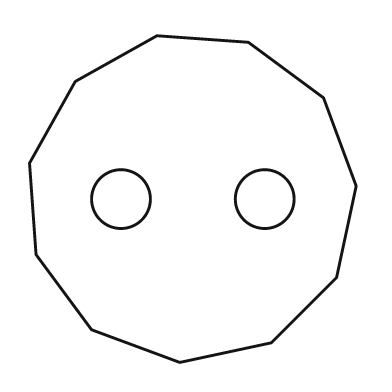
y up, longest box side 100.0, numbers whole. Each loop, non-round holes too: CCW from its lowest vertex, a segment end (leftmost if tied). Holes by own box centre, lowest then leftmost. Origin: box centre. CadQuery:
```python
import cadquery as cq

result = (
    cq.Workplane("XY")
    .moveTo(-4.0, -50.0)
    .lineTo(24.0, -44.0)
    .lineTo(44.0, -24.0)
    .lineTo(50.0, 4.0)
    .lineTo(40.0, 31.0)
    .lineTo(17.0, 48.0)
    .lineTo(-11.0, 50.0)
    .lineTo(-36.0, 36.0)
    .lineTo(-50.0, 11.0)
    .lineTo(-48.0, -17.0)
    .lineTo(-31.0, -40.0)
    .close()
    .moveTo(-22.0, 0.0)
    .circle(9.0)
    .moveTo(22.0, 0.0)
    .circle(9.0)
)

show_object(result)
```